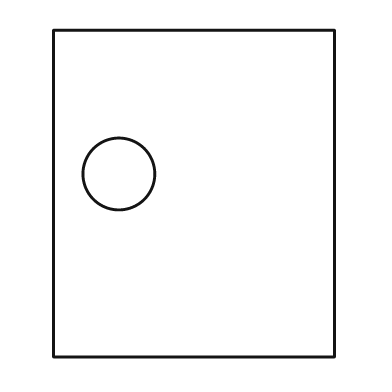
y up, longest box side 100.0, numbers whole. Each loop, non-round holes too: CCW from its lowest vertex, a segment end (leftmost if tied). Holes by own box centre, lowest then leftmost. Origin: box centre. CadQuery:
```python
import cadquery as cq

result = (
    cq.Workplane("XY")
    .moveTo(-43.0, -50.0)
    .lineTo(43.0, -50.0)
    .lineTo(43.0, 50.0)
    .lineTo(-43.0, 50.0)
    .close()
    .moveTo(-23.0, 6.0)
    .circle(11.0)
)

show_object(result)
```